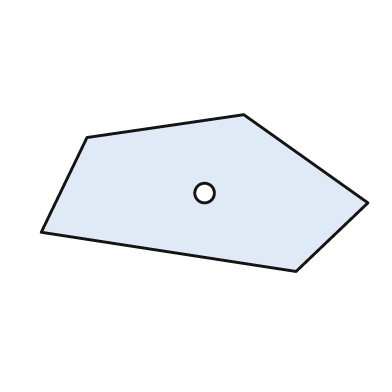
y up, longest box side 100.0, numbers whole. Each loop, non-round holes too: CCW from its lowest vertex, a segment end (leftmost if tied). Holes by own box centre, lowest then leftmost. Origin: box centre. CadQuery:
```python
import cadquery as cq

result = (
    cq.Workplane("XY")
    .moveTo(28.0, -24.0)
    .lineTo(50.0, -3.0)
    .lineTo(12.0, 24.0)
    .lineTo(-36.0, 17.0)
    .lineTo(-50.0, -12.0)
    .close()
    .moveTo(0.0, 0.0)
    .circle(3.0)
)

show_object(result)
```